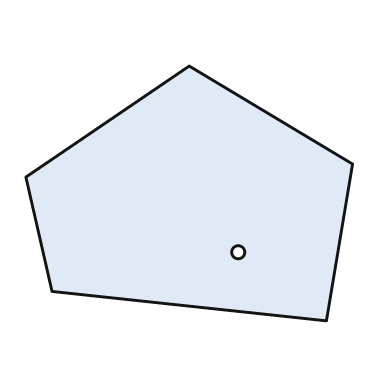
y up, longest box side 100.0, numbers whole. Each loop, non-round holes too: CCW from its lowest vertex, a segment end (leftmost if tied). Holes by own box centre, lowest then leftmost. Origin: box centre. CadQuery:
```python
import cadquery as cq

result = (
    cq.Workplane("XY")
    .moveTo(42.0, -39.0)
    .lineTo(50.0, 9.0)
    .lineTo(0.0, 39.0)
    .lineTo(-50.0, 5.0)
    .lineTo(-42.0, -30.0)
    .close()
    .moveTo(15.0, -18.0)
    .circle(2.0)
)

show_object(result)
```